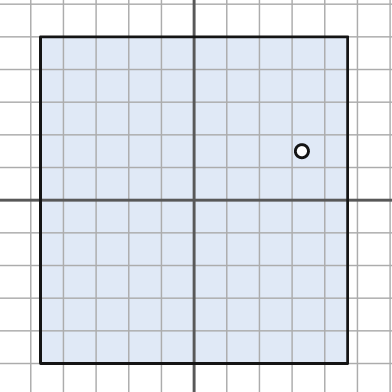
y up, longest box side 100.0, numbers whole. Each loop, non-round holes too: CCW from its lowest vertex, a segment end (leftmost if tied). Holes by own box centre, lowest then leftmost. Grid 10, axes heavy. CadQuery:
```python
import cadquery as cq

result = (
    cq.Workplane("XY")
    .moveTo(-47.0, -50.0)
    .lineTo(47.0, -50.0)
    .lineTo(47.0, 50.0)
    .lineTo(-47.0, 50.0)
    .close()
    .moveTo(33.0, 15.0)
    .circle(2.0)
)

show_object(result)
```